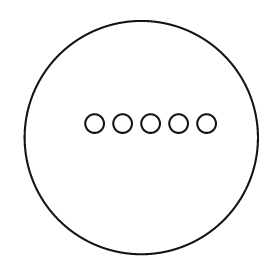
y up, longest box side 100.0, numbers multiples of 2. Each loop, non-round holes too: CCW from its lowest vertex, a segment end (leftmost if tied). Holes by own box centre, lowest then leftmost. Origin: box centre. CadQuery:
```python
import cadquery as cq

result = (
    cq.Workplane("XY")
    .moveTo(0.0, 0.0)
    .circle(50.0)
    .moveTo(-20.0, 6.0)
    .circle(4.0)
    .moveTo(-8.0, 6.0)
    .circle(4.0)
    .moveTo(4.0, 6.0)
    .circle(4.0)
    .moveTo(16.0, 6.0)
    .circle(4.0)
    .moveTo(28.0, 6.0)
    .circle(4.0)
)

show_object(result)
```